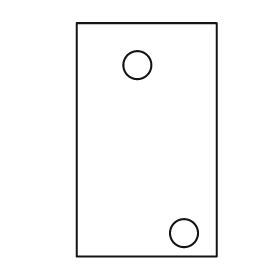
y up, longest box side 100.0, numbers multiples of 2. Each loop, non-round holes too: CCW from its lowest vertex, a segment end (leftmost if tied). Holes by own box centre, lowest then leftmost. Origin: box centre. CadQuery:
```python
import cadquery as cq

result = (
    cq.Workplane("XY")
    .moveTo(-30.0, -50.0)
    .lineTo(30.0, -50.0)
    .lineTo(30.0, 50.0)
    .lineTo(-30.0, 50.0)
    .close()
    .moveTo(16.0, -40.0)
    .circle(6.0)
    .moveTo(-4.0, 32.0)
    .circle(6.0)
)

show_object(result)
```